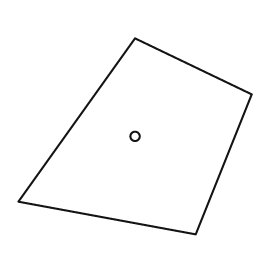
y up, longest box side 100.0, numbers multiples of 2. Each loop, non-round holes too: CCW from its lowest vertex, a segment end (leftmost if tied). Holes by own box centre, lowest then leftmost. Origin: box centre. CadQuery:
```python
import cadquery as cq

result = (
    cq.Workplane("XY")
    .moveTo(26.0, -42.0)
    .lineTo(50.0, 18.0)
    .lineTo(0.0, 42.0)
    .lineTo(-50.0, -28.0)
    .close()
    .moveTo(0.0, 0.0)
    .circle(2.0)
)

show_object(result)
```